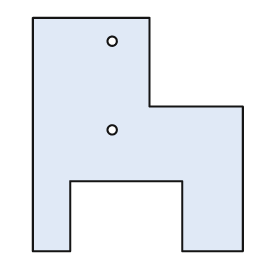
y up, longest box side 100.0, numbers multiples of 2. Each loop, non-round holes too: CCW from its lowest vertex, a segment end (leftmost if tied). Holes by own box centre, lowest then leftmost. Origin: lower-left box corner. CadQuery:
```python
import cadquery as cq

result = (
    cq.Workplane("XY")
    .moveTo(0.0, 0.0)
    .lineTo(16.0, 0.0)
    .lineTo(16.0, 30.0)
    .lineTo(64.0, 30.0)
    .lineTo(64.0, 0.0)
    .lineTo(90.0, 0.0)
    .lineTo(90.0, 62.0)
    .lineTo(50.0, 62.0)
    .lineTo(50.0, 100.0)
    .lineTo(0.0, 100.0)
    .close()
    .moveTo(34.0, 52.0)
    .circle(2.0)
    .moveTo(34.0, 90.0)
    .circle(2.0)
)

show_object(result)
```